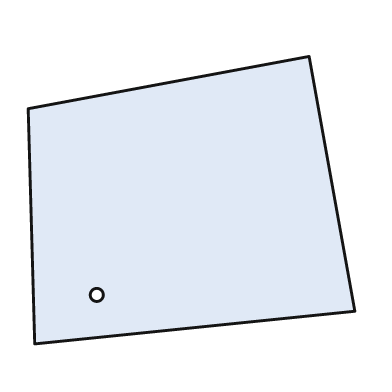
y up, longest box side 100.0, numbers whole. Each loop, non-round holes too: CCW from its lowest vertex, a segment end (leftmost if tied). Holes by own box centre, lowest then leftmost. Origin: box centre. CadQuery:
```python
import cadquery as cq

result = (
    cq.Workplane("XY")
    .moveTo(-48.0, -44.0)
    .lineTo(50.0, -34.0)
    .lineTo(36.0, 44.0)
    .lineTo(-50.0, 28.0)
    .close()
    .moveTo(-29.0, -29.0)
    .circle(2.0)
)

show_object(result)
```